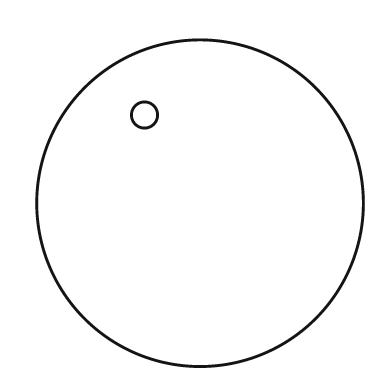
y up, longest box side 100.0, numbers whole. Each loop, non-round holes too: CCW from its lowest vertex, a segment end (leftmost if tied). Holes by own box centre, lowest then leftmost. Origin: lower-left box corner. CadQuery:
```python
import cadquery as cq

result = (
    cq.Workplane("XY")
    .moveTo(50.0, 50.0)
    .circle(50.0)
    .moveTo(33.0, 77.0)
    .circle(4.0)
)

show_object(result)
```